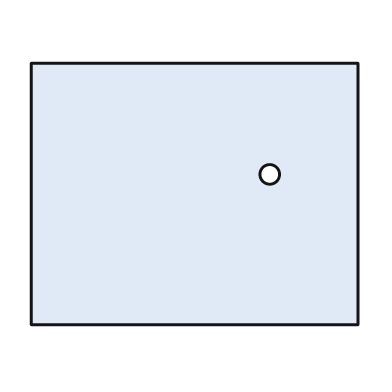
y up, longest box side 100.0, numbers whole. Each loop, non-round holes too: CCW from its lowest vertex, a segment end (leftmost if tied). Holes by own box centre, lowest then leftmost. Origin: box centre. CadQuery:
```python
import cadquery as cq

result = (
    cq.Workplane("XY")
    .moveTo(-50.0, -40.0)
    .lineTo(50.0, -40.0)
    .lineTo(50.0, 40.0)
    .lineTo(-50.0, 40.0)
    .close()
    .moveTo(23.0, 6.0)
    .circle(3.0)
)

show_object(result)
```